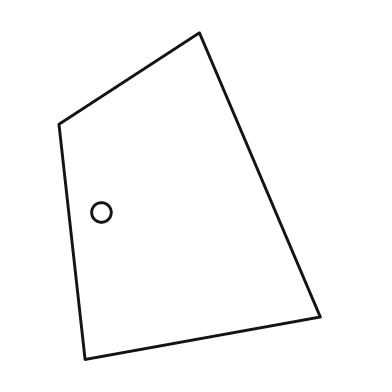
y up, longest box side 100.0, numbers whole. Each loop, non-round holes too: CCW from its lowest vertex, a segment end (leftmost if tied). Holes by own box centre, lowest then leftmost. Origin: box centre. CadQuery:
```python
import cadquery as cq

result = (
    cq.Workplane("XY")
    .moveTo(-32.0, -50.0)
    .lineTo(40.0, -37.0)
    .lineTo(3.0, 50.0)
    .lineTo(-40.0, 22.0)
    .close()
    .moveTo(-27.0, -5.0)
    .circle(3.0)
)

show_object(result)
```